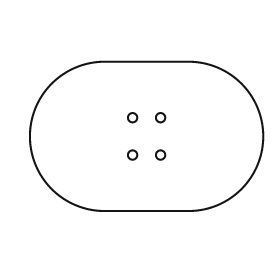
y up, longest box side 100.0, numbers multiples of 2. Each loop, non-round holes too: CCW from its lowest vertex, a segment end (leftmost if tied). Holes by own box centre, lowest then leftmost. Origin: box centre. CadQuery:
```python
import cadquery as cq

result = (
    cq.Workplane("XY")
    .moveTo(-18.0, -32.0)
    .lineTo(18.0, -32.0)
    .threePointArc((50.0, 0.0), (18.0, 32.0))
    .lineTo(-18.0, 32.0)
    .threePointArc((-50.0, 0.0), (-18.0, -32.0))
    .close()
    .moveTo(-6.0, -8.0)
    .circle(2.0)
    .moveTo(6.0, -8.0)
    .circle(2.0)
    .moveTo(-6.0, 8.0)
    .circle(2.0)
    .moveTo(6.0, 8.0)
    .circle(2.0)
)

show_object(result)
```